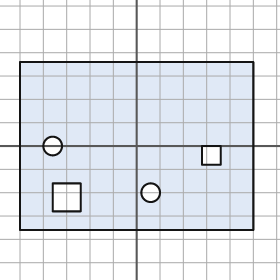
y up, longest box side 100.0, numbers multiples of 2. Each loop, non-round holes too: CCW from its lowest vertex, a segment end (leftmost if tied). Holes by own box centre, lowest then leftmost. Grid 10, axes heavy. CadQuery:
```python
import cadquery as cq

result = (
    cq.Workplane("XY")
    .moveTo(-50.0, -36.0)
    .lineTo(50.0, -36.0)
    .lineTo(50.0, 36.0)
    .lineTo(-50.0, 36.0)
    .close()
    .moveTo(-36.0, -28.0)
    .lineTo(-24.0, -28.0)
    .lineTo(-24.0, -16.0)
    .lineTo(-36.0, -16.0)
    .close()
    .moveTo(6.0, -20.0)
    .circle(4.0)
    .moveTo(28.0, -8.0)
    .lineTo(36.0, -8.0)
    .lineTo(36.0, 0.0)
    .lineTo(28.0, 0.0)
    .close()
    .moveTo(-36.0, 0.0)
    .circle(4.0)
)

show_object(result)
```